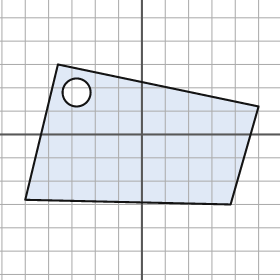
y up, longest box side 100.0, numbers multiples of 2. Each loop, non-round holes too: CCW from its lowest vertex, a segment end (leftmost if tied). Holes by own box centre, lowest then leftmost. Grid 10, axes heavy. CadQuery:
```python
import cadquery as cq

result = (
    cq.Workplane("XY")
    .moveTo(38.0, -30.0)
    .lineTo(50.0, 12.0)
    .lineTo(-36.0, 30.0)
    .lineTo(-50.0, -28.0)
    .close()
    .moveTo(-28.0, 18.0)
    .circle(6.0)
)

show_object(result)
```